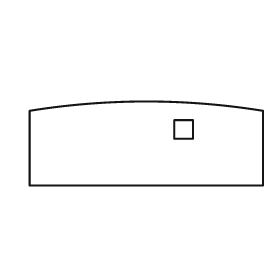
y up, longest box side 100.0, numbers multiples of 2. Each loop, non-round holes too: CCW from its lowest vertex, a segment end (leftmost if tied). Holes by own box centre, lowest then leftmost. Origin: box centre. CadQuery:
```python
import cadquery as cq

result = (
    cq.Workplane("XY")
    .moveTo(-50.0, -18.0)
    .lineTo(50.0, -18.0)
    .lineTo(50.0, 14.0)
    .threePointArc((0.0, 18.0), (-50.0, 14.0))
    .close()
    .moveTo(12.0, 2.0)
    .lineTo(20.0, 2.0)
    .lineTo(20.0, 10.0)
    .lineTo(12.0, 10.0)
    .close()
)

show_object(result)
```